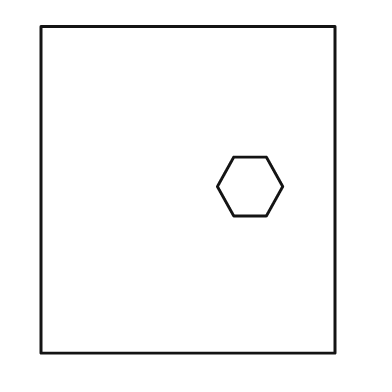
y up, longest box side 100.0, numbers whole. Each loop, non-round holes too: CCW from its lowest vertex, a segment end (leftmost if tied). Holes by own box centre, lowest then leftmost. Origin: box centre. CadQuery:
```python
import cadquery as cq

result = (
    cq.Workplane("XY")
    .moveTo(-45.0, -50.0)
    .lineTo(45.0, -50.0)
    .lineTo(45.0, 50.0)
    .lineTo(-45.0, 50.0)
    .close()
    .moveTo(14.0, -8.0)
    .lineTo(24.0, -8.0)
    .lineTo(29.0, 1.0)
    .lineTo(24.0, 10.0)
    .lineTo(14.0, 10.0)
    .lineTo(9.0, 1.0)
    .close()
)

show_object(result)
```